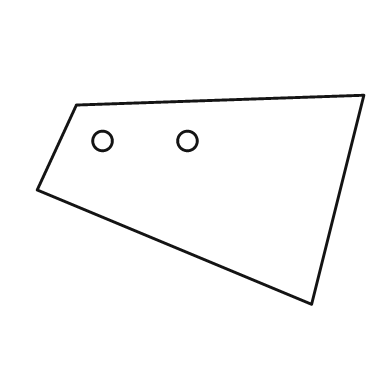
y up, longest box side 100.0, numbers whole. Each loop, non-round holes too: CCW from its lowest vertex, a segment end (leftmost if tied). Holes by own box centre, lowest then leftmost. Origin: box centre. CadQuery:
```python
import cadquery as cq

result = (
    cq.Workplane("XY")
    .moveTo(34.0, -32.0)
    .lineTo(50.0, 32.0)
    .lineTo(-38.0, 29.0)
    .lineTo(-50.0, 3.0)
    .close()
    .moveTo(-30.0, 18.0)
    .circle(3.0)
    .moveTo(-4.0, 18.0)
    .circle(3.0)
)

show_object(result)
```